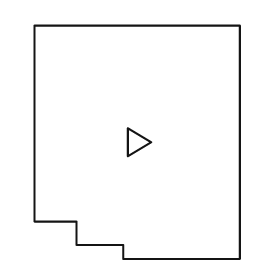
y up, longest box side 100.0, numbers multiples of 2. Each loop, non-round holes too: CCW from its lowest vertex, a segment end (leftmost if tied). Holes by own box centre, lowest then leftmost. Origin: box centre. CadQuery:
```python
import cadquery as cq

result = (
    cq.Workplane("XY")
    .moveTo(-6.0, -50.0)
    .lineTo(44.0, -50.0)
    .lineTo(44.0, 50.0)
    .lineTo(-44.0, 50.0)
    .lineTo(-44.0, -34.0)
    .lineTo(-26.0, -34.0)
    .lineTo(-26.0, -44.0)
    .lineTo(-6.0, -44.0)
    .close()
    .moveTo(-4.0, -6.0)
    .lineTo(6.0, 0.0)
    .lineTo(-4.0, 6.0)
    .close()
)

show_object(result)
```